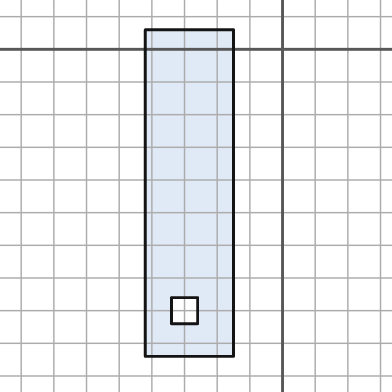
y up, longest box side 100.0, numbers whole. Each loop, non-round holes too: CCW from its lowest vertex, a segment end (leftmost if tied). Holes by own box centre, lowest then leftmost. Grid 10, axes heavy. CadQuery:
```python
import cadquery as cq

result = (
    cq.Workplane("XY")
    .moveTo(-42.0, -94.0)
    .lineTo(-15.0, -94.0)
    .lineTo(-15.0, 6.0)
    .lineTo(-42.0, 6.0)
    .close()
    .moveTo(-34.0, -84.0)
    .lineTo(-26.0, -84.0)
    .lineTo(-26.0, -76.0)
    .lineTo(-34.0, -76.0)
    .close()
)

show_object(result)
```